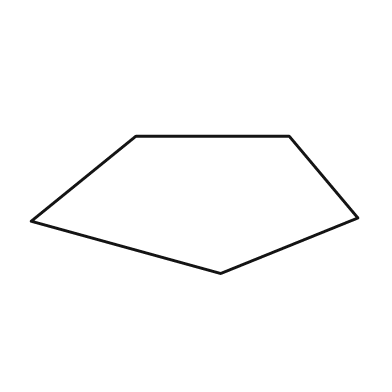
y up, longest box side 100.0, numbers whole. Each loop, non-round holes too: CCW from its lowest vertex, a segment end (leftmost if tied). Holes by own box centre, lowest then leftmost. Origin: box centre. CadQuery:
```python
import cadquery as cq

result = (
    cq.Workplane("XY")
    .moveTo(8.0, -21.0)
    .lineTo(50.0, -4.0)
    .lineTo(29.0, 21.0)
    .lineTo(-18.0, 21.0)
    .lineTo(-50.0, -5.0)
    .close()
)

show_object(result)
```